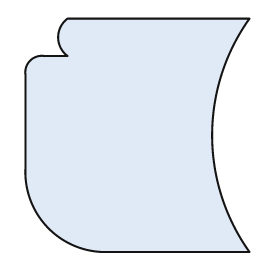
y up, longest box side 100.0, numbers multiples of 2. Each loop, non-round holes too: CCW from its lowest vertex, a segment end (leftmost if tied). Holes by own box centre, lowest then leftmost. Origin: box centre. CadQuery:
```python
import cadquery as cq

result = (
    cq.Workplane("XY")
    .moveTo(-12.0, -50.0)
    .lineTo(48.0, -50.0)
    .threePointArc((32.0, 0.0), (48.0, 50.0))
    .lineTo(-30.0, 50.0)
    .threePointArc((-34.0, 42.0), (-30.0, 34.0))
    .lineTo(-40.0, 34.0)
    .threePointArc((-46.0, 32.0), (-48.0, 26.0))
    .lineTo(-48.0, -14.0)
    .threePointArc((-38.0, -40.0), (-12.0, -50.0))
    .close()
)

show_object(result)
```